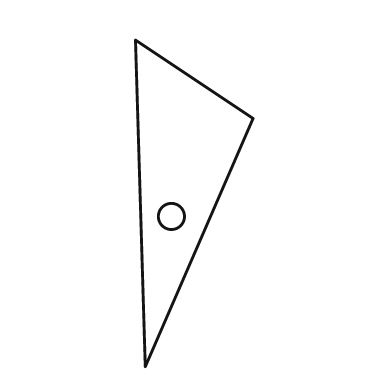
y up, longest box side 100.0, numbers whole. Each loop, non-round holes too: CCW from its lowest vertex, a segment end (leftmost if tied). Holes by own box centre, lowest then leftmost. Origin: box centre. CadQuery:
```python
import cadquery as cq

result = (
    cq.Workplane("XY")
    .moveTo(-15.0, -50.0)
    .lineTo(18.0, 26.0)
    .lineTo(-18.0, 50.0)
    .close()
    .moveTo(-7.0, -4.0)
    .circle(4.0)
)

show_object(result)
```